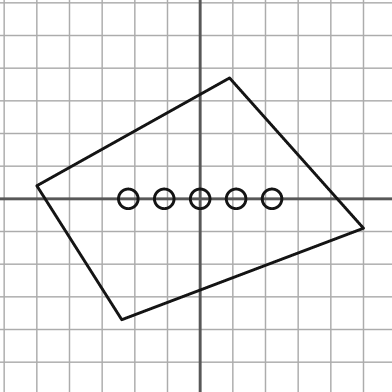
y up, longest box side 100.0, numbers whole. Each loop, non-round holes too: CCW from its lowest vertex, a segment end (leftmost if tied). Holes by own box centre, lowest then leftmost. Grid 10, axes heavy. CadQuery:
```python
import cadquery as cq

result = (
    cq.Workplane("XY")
    .moveTo(-24.0, -37.0)
    .lineTo(50.0, -9.0)
    .lineTo(9.0, 37.0)
    .lineTo(-50.0, 4.0)
    .close()
    .moveTo(-22.0, 0.0)
    .circle(3.0)
    .moveTo(-11.0, 0.0)
    .circle(3.0)
    .moveTo(0.0, 0.0)
    .circle(3.0)
    .moveTo(11.0, 0.0)
    .circle(3.0)
    .moveTo(22.0, 0.0)
    .circle(3.0)
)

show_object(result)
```